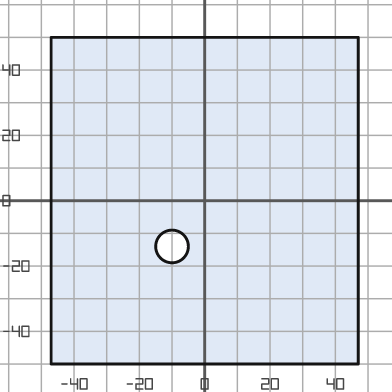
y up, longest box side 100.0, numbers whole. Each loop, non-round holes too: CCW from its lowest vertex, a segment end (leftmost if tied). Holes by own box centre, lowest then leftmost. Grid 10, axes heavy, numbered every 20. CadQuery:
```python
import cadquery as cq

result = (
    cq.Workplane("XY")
    .moveTo(-47.0, -50.0)
    .lineTo(47.0, -50.0)
    .lineTo(47.0, 50.0)
    .lineTo(-47.0, 50.0)
    .close()
    .moveTo(-10.0, -14.0)
    .circle(5.0)
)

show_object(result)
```